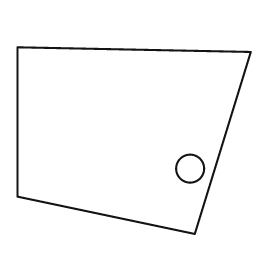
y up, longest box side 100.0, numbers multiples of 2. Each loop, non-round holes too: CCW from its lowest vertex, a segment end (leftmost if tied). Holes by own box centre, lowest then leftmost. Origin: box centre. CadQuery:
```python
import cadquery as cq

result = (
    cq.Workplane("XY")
    .moveTo(26.0, -40.0)
    .lineTo(50.0, 38.0)
    .lineTo(-50.0, 40.0)
    .lineTo(-50.0, -24.0)
    .close()
    .moveTo(24.0, -12.0)
    .circle(6.0)
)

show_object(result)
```